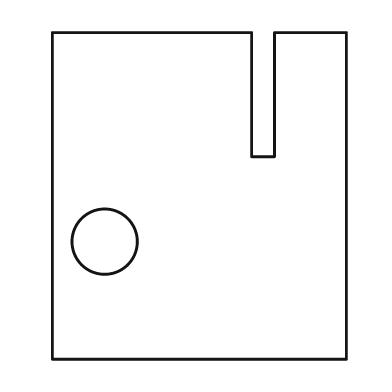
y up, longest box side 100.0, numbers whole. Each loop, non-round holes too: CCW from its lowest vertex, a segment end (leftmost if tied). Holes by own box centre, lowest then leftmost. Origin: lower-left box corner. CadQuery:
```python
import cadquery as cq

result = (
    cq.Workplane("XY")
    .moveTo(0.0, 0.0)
    .lineTo(90.0, 0.0)
    .lineTo(90.0, 100.0)
    .lineTo(68.0, 100.0)
    .lineTo(68.0, 62.0)
    .lineTo(61.0, 62.0)
    .lineTo(61.0, 100.0)
    .lineTo(0.0, 100.0)
    .close()
    .moveTo(16.0, 36.0)
    .circle(10.0)
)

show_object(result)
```